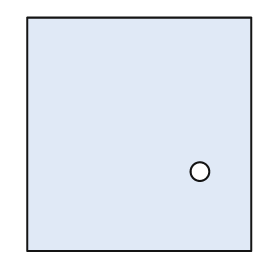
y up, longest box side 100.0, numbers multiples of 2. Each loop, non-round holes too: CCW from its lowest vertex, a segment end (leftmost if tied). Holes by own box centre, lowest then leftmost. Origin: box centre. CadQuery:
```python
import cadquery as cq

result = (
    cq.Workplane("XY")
    .moveTo(-48.0, -50.0)
    .lineTo(48.0, -50.0)
    .lineTo(48.0, 50.0)
    .lineTo(-48.0, 50.0)
    .close()
    .moveTo(26.0, -16.0)
    .circle(4.0)
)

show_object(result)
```